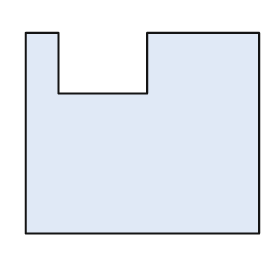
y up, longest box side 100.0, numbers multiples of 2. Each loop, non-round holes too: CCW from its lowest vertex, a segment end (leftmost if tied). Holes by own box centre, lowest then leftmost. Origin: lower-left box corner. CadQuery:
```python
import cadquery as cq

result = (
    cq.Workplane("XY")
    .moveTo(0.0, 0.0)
    .lineTo(100.0, 0.0)
    .lineTo(100.0, 86.0)
    .lineTo(52.0, 86.0)
    .lineTo(52.0, 60.0)
    .lineTo(14.0, 60.0)
    .lineTo(14.0, 86.0)
    .lineTo(0.0, 86.0)
    .close()
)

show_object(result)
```